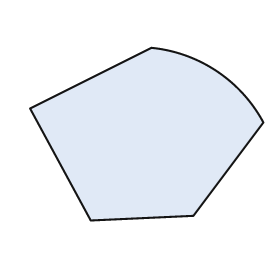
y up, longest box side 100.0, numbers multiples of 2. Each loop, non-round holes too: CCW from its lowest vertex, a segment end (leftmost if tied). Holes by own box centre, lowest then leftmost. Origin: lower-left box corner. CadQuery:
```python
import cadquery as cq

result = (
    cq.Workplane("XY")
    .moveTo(26.0, 0.0)
    .lineTo(70.0, 2.0)
    .lineTo(100.0, 42.0)
    .threePointArc((80.0, 64.0), (52.0, 74.0))
    .lineTo(0.0, 48.0)
    .close()
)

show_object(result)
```